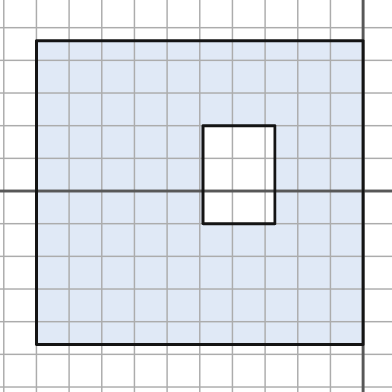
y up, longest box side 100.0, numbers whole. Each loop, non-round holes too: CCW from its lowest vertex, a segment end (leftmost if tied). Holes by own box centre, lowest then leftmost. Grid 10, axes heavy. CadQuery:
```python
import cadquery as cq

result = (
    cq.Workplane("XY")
    .moveTo(-100.0, -47.0)
    .lineTo(0.0, -47.0)
    .lineTo(0.0, 46.0)
    .lineTo(-100.0, 46.0)
    .close()
    .moveTo(-49.0, -10.0)
    .lineTo(-27.0, -10.0)
    .lineTo(-27.0, 20.0)
    .lineTo(-49.0, 20.0)
    .close()
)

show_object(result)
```